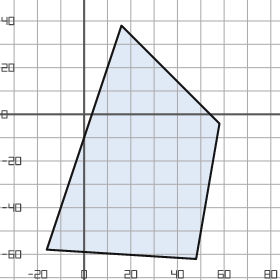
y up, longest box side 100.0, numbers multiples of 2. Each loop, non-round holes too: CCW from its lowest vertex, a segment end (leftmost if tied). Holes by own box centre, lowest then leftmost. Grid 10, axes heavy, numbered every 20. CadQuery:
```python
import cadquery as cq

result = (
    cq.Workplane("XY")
    .moveTo(48.0, -62.0)
    .lineTo(58.0, -4.0)
    .lineTo(16.0, 38.0)
    .lineTo(-16.0, -58.0)
    .close()
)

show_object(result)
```